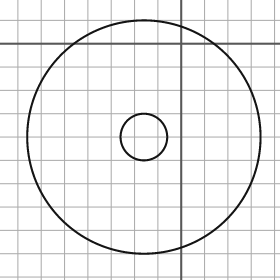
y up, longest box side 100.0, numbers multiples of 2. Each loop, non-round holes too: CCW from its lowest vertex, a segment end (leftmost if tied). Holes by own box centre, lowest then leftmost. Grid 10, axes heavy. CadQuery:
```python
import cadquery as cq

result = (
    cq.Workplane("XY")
    .moveTo(-16.0, -40.0)
    .circle(50.0)
    .moveTo(-16.0, -40.0)
    .circle(10.0)
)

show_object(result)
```